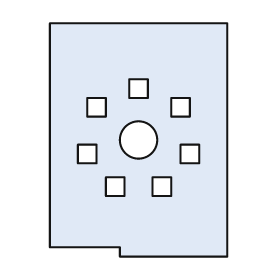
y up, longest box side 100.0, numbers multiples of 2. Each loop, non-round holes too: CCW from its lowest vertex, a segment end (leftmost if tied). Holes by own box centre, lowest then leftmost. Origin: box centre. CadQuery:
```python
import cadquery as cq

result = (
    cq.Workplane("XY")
    .moveTo(-8.0, -50.0)
    .lineTo(38.0, -50.0)
    .lineTo(38.0, 50.0)
    .lineTo(-38.0, 50.0)
    .lineTo(-38.0, -46.0)
    .lineTo(-8.0, -46.0)
    .close()
    .moveTo(-14.0, -24.0)
    .lineTo(-6.0, -24.0)
    .lineTo(-6.0, -16.0)
    .lineTo(-14.0, -16.0)
    .close()
    .moveTo(6.0, -24.0)
    .lineTo(14.0, -24.0)
    .lineTo(14.0, -16.0)
    .lineTo(6.0, -16.0)
    .close()
    .moveTo(-26.0, -10.0)
    .lineTo(-18.0, -10.0)
    .lineTo(-18.0, -2.0)
    .lineTo(-26.0, -2.0)
    .close()
    .moveTo(18.0, -10.0)
    .lineTo(26.0, -10.0)
    .lineTo(26.0, -2.0)
    .lineTo(18.0, -2.0)
    .close()
    .moveTo(0.0, 0.0)
    .circle(8.0)
    .moveTo(-22.0, 10.0)
    .lineTo(-14.0, 10.0)
    .lineTo(-14.0, 18.0)
    .lineTo(-22.0, 18.0)
    .close()
    .moveTo(14.0, 10.0)
    .lineTo(22.0, 10.0)
    .lineTo(22.0, 18.0)
    .lineTo(14.0, 18.0)
    .close()
    .moveTo(-4.0, 18.0)
    .lineTo(4.0, 18.0)
    .lineTo(4.0, 26.0)
    .lineTo(-4.0, 26.0)
    .close()
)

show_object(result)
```